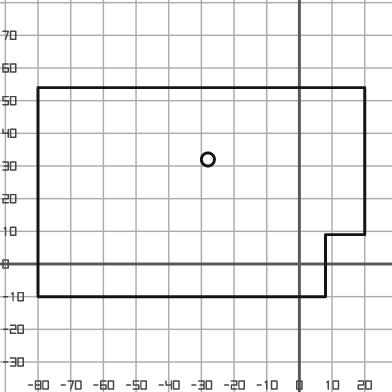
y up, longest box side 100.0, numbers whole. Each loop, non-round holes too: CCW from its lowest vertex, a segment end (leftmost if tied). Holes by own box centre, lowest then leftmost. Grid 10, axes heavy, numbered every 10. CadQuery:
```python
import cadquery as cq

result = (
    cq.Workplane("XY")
    .moveTo(-80.0, -10.0)
    .lineTo(8.0, -10.0)
    .lineTo(8.0, 9.0)
    .lineTo(20.0, 9.0)
    .lineTo(20.0, 54.0)
    .lineTo(-80.0, 54.0)
    .close()
    .moveTo(-28.0, 32.0)
    .circle(2.0)
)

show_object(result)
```